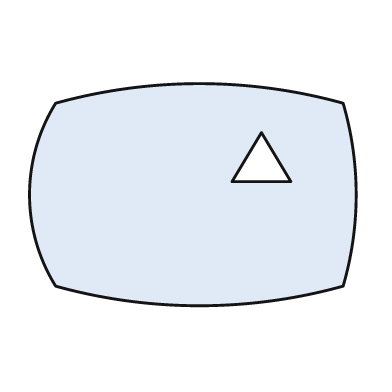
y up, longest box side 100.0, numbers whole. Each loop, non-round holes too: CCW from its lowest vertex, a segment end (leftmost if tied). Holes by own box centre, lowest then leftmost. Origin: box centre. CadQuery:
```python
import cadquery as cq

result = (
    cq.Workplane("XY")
    .moveTo(-42.0, -28.0)
    .threePointArc((2.0, -34.0), (46.0, -28.0))
    .threePointArc((50.0, 0.0), (46.0, 28.0))
    .threePointArc((2.0, 34.0), (-42.0, 28.0))
    .threePointArc((-50.0, 0.0), (-42.0, -28.0))
    .close()
    .moveTo(12.0, 4.0)
    .lineTo(30.0, 4.0)
    .lineTo(21.0, 19.0)
    .close()
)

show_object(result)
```